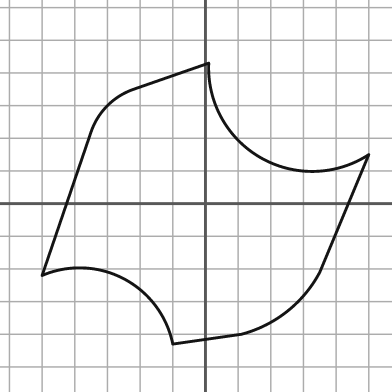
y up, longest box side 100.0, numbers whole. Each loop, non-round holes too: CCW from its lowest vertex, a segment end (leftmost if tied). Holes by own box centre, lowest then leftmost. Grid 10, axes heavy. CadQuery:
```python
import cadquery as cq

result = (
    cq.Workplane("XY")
    .moveTo(-10.0, -43.0)
    .lineTo(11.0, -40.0)
    .threePointArc((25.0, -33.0), (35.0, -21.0))
    .lineTo(50.0, 15.0)
    .threePointArc((17.0, 14.0), (1.0, 43.0))
    .lineTo(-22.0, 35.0)
    .threePointArc((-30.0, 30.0), (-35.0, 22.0))
    .lineTo(-50.0, -22.0)
    .threePointArc((-25.0, -23.0), (-10.0, -43.0))
    .close()
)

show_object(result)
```